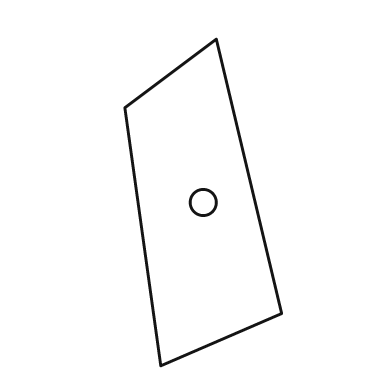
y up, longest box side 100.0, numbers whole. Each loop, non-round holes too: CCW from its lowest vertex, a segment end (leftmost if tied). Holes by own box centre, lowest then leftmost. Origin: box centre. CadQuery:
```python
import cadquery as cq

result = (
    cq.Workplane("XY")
    .moveTo(-13.0, -50.0)
    .lineTo(24.0, -34.0)
    .lineTo(4.0, 50.0)
    .lineTo(-24.0, 29.0)
    .close()
    .moveTo(0.0, 0.0)
    .circle(4.0)
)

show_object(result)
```